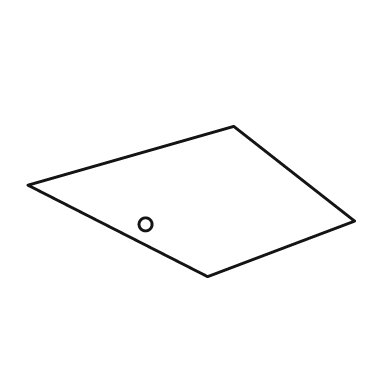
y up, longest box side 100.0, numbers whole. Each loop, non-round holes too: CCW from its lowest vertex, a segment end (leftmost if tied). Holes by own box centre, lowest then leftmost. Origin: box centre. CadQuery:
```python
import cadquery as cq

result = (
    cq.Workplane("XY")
    .moveTo(5.0, -23.0)
    .lineTo(50.0, -6.0)
    .lineTo(13.0, 23.0)
    .lineTo(-50.0, 5.0)
    .close()
    .moveTo(-14.0, -7.0)
    .circle(2.0)
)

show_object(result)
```